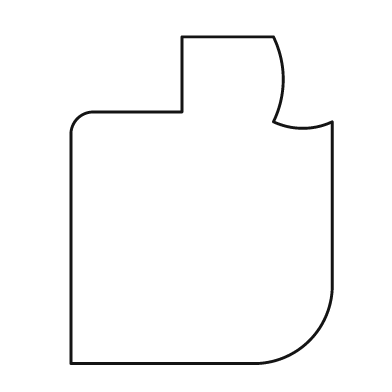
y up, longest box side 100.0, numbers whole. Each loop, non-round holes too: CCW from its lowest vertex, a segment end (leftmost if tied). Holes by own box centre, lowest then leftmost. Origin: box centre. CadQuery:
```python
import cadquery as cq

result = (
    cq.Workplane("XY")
    .moveTo(-40.0, -50.0)
    .lineTo(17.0, -50.0)
    .threePointArc((33.0, -43.0), (40.0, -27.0))
    .lineTo(40.0, 24.0)
    .threePointArc((31.0, 22.0), (22.0, 24.0))
    .threePointArc((25.0, 37.0), (22.0, 50.0))
    .lineTo(-6.0, 50.0)
    .lineTo(-6.0, 27.0)
    .lineTo(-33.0, 27.0)
    .threePointArc((-38.0, 25.0), (-40.0, 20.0))
    .close()
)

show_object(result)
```